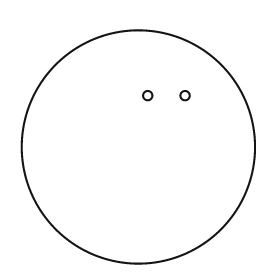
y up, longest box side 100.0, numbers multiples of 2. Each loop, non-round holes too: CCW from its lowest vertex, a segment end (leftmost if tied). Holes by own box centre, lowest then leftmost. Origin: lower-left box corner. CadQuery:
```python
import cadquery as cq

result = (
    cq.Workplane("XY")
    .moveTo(50.0, 50.0)
    .circle(50.0)
    .moveTo(54.0, 72.0)
    .circle(2.0)
    .moveTo(70.0, 72.0)
    .circle(2.0)
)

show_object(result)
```